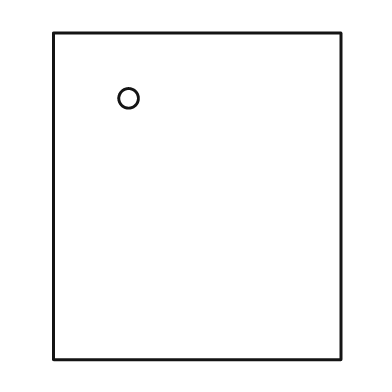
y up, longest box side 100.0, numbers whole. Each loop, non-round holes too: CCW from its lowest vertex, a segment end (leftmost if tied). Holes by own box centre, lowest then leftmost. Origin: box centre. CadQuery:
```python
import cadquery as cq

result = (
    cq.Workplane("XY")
    .moveTo(-44.0, -50.0)
    .lineTo(44.0, -50.0)
    .lineTo(44.0, 50.0)
    .lineTo(-44.0, 50.0)
    .close()
    .moveTo(-21.0, 30.0)
    .circle(3.0)
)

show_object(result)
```